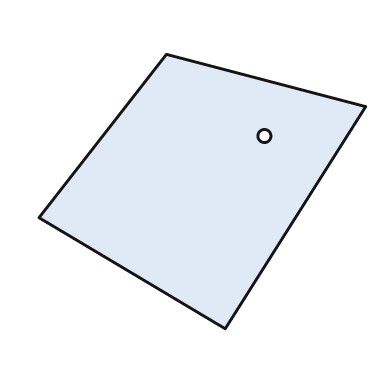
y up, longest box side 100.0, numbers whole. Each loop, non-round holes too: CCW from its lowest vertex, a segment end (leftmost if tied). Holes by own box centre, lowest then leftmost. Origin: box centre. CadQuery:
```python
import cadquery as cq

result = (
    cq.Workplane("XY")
    .moveTo(7.0, -42.0)
    .lineTo(50.0, 26.0)
    .lineTo(-11.0, 42.0)
    .lineTo(-50.0, -8.0)
    .close()
    .moveTo(19.0, 17.0)
    .circle(2.0)
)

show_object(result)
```